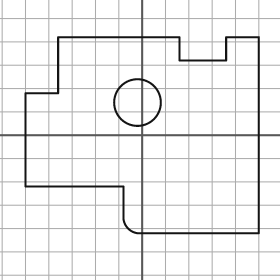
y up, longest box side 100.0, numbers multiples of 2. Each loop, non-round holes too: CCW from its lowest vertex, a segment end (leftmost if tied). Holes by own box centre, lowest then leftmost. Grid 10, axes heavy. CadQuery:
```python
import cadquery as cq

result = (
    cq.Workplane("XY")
    .moveTo(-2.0, -42.0)
    .lineTo(50.0, -42.0)
    .lineTo(50.0, 42.0)
    .lineTo(36.0, 42.0)
    .lineTo(36.0, 32.0)
    .lineTo(16.0, 32.0)
    .lineTo(16.0, 42.0)
    .lineTo(-36.0, 42.0)
    .lineTo(-36.0, 18.0)
    .lineTo(-50.0, 18.0)
    .lineTo(-50.0, -22.0)
    .lineTo(-8.0, -22.0)
    .lineTo(-8.0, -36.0)
    .threePointArc((-6.0, -40.0), (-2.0, -42.0))
    .close()
    .moveTo(-2.0, 14.0)
    .circle(10.0)
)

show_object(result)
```